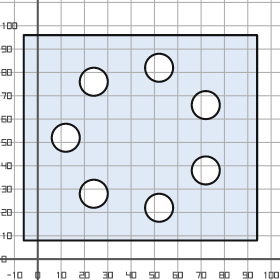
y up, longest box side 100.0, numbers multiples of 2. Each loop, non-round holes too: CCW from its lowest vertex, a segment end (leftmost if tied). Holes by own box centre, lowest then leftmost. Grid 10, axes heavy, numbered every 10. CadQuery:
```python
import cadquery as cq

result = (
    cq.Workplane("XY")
    .moveTo(-6.0, 8.0)
    .lineTo(94.0, 8.0)
    .lineTo(94.0, 96.0)
    .lineTo(-6.0, 96.0)
    .close()
    .moveTo(52.0, 22.0)
    .circle(6.0)
    .moveTo(24.0, 28.0)
    .circle(6.0)
    .moveTo(72.0, 38.0)
    .circle(6.0)
    .moveTo(12.0, 52.0)
    .circle(6.0)
    .moveTo(72.0, 66.0)
    .circle(6.0)
    .moveTo(24.0, 76.0)
    .circle(6.0)
    .moveTo(52.0, 82.0)
    .circle(6.0)
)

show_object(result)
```